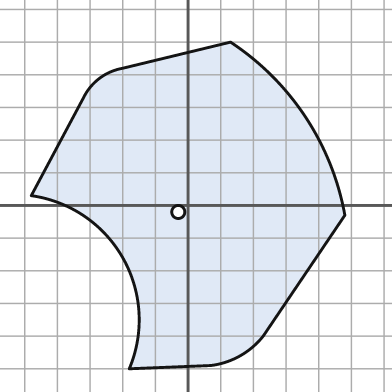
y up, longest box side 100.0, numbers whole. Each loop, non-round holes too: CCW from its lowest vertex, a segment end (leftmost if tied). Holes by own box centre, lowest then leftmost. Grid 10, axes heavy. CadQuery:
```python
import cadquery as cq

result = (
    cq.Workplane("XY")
    .moveTo(-18.0, -50.0)
    .lineTo(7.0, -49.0)
    .threePointArc((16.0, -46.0), (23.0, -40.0))
    .lineTo(48.0, -3.0)
    .threePointArc((36.0, 27.0), (13.0, 50.0))
    .lineTo(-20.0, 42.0)
    .threePointArc((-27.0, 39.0), (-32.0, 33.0))
    .lineTo(-48.0, 3.0)
    .threePointArc((-20.0, -16.0), (-18.0, -50.0))
    .close()
    .moveTo(-3.0, -2.0)
    .circle(2.0)
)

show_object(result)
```